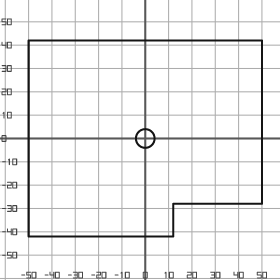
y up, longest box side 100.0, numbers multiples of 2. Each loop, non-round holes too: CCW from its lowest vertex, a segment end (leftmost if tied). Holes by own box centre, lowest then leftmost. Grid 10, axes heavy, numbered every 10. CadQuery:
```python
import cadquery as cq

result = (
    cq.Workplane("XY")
    .moveTo(-50.0, -42.0)
    .lineTo(12.0, -42.0)
    .lineTo(12.0, -28.0)
    .lineTo(50.0, -28.0)
    .lineTo(50.0, 42.0)
    .lineTo(-50.0, 42.0)
    .close()
    .moveTo(0.0, 0.0)
    .circle(4.0)
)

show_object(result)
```